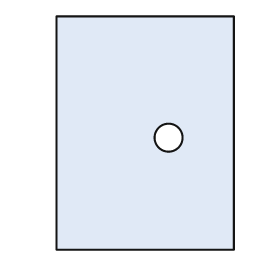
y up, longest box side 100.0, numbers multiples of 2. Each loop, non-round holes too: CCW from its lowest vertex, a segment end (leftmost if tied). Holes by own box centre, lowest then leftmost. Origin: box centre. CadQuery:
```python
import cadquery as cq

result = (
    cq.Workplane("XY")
    .moveTo(-38.0, -50.0)
    .lineTo(38.0, -50.0)
    .lineTo(38.0, 50.0)
    .lineTo(-38.0, 50.0)
    .close()
    .moveTo(10.0, -2.0)
    .circle(6.0)
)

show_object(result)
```